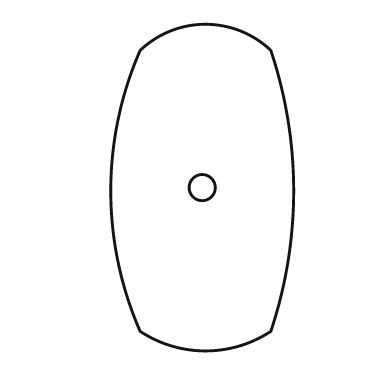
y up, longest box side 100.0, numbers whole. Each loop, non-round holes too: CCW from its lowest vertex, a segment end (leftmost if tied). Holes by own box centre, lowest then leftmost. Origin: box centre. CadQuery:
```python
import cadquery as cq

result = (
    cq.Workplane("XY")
    .moveTo(-19.0, -44.0)
    .threePointArc((1.0, -50.0), (21.0, -44.0))
    .threePointArc((28.0, -1.0), (21.0, 42.0))
    .threePointArc((1.0, 50.0), (-19.0, 42.0))
    .threePointArc((-28.0, -1.0), (-19.0, -44.0))
    .close()
    .moveTo(0.0, 0.0)
    .circle(4.0)
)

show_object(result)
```